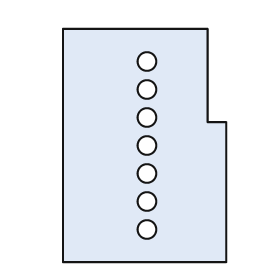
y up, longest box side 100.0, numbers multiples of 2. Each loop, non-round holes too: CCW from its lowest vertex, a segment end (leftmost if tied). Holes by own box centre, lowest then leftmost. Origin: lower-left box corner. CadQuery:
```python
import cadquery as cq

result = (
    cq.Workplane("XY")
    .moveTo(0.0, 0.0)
    .lineTo(70.0, 0.0)
    .lineTo(70.0, 60.0)
    .lineTo(62.0, 60.0)
    .lineTo(62.0, 100.0)
    .lineTo(0.0, 100.0)
    .close()
    .moveTo(36.0, 14.0)
    .circle(4.0)
    .moveTo(36.0, 26.0)
    .circle(4.0)
    .moveTo(36.0, 38.0)
    .circle(4.0)
    .moveTo(36.0, 50.0)
    .circle(4.0)
    .moveTo(36.0, 62.0)
    .circle(4.0)
    .moveTo(36.0, 74.0)
    .circle(4.0)
    .moveTo(36.0, 86.0)
    .circle(4.0)
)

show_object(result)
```